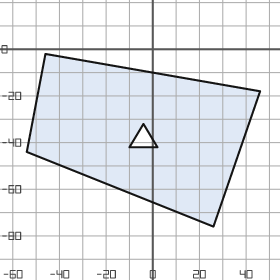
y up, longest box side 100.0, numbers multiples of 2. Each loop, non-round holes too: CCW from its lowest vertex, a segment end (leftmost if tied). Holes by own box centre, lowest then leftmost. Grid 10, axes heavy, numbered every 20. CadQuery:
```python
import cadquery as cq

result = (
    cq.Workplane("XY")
    .moveTo(26.0, -76.0)
    .lineTo(46.0, -18.0)
    .lineTo(-46.0, -2.0)
    .lineTo(-54.0, -44.0)
    .close()
    .moveTo(-10.0, -42.0)
    .lineTo(2.0, -42.0)
    .lineTo(-4.0, -32.0)
    .close()
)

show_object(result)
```